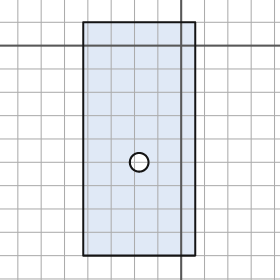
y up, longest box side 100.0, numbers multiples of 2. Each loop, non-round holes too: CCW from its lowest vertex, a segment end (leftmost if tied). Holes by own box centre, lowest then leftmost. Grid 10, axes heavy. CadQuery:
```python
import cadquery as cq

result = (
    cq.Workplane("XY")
    .moveTo(-42.0, -90.0)
    .lineTo(6.0, -90.0)
    .lineTo(6.0, 10.0)
    .lineTo(-42.0, 10.0)
    .close()
    .moveTo(-18.0, -50.0)
    .circle(4.0)
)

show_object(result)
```